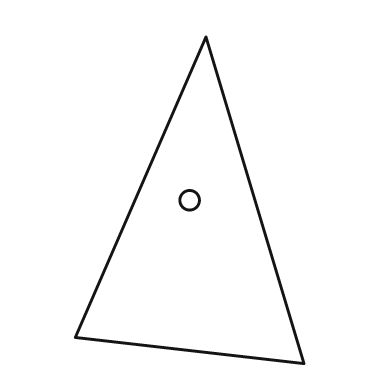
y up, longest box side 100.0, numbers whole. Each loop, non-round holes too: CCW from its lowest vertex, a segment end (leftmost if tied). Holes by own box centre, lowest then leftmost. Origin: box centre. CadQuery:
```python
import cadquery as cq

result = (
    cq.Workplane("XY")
    .moveTo(35.0, -50.0)
    .lineTo(5.0, 50.0)
    .lineTo(-35.0, -42.0)
    .close()
    .moveTo(0.0, 0.0)
    .circle(3.0)
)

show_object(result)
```